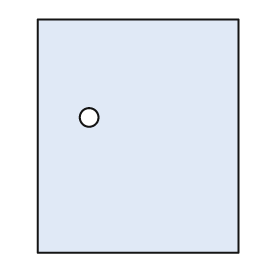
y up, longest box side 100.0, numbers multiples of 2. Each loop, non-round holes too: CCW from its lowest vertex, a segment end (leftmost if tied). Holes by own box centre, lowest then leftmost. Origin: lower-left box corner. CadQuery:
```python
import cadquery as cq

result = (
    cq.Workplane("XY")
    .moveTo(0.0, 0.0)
    .lineTo(86.0, 0.0)
    .lineTo(86.0, 100.0)
    .lineTo(0.0, 100.0)
    .close()
    .moveTo(22.0, 58.0)
    .circle(4.0)
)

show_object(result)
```